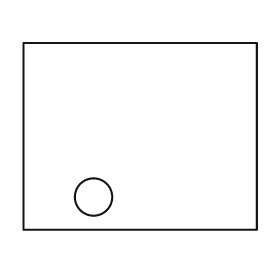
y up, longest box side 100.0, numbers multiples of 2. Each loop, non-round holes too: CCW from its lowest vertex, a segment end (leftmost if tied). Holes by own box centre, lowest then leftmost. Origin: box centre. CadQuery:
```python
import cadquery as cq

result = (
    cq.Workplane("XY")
    .moveTo(-50.0, -40.0)
    .lineTo(50.0, -40.0)
    .lineTo(50.0, 40.0)
    .lineTo(-50.0, 40.0)
    .close()
    .moveTo(-20.0, -26.0)
    .circle(8.0)
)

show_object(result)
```